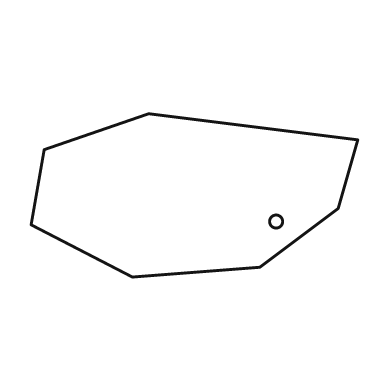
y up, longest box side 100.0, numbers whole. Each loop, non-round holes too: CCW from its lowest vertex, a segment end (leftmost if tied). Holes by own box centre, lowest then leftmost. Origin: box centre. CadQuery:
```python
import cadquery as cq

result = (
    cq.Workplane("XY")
    .moveTo(-19.0, -25.0)
    .lineTo(20.0, -22.0)
    .lineTo(44.0, -4.0)
    .lineTo(50.0, 17.0)
    .lineTo(-14.0, 25.0)
    .lineTo(-46.0, 14.0)
    .lineTo(-50.0, -9.0)
    .close()
    .moveTo(25.0, -8.0)
    .circle(2.0)
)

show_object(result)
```